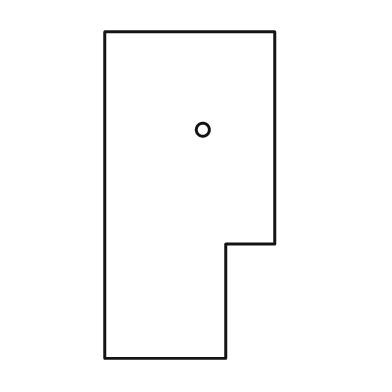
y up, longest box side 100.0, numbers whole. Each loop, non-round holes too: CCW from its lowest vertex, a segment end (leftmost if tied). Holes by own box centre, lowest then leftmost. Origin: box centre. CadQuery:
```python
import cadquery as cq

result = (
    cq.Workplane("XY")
    .moveTo(-26.0, -50.0)
    .lineTo(11.0, -50.0)
    .lineTo(11.0, -15.0)
    .lineTo(26.0, -15.0)
    .lineTo(26.0, 50.0)
    .lineTo(-26.0, 50.0)
    .close()
    .moveTo(4.0, 20.0)
    .circle(2.0)
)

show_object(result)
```